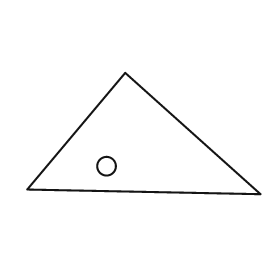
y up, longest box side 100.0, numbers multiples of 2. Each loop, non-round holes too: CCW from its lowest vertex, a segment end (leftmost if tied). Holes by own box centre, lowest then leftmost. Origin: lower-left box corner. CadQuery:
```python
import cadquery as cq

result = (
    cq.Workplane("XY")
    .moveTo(100.0, 0.0)
    .lineTo(42.0, 52.0)
    .lineTo(0.0, 2.0)
    .close()
    .moveTo(34.0, 12.0)
    .circle(4.0)
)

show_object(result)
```